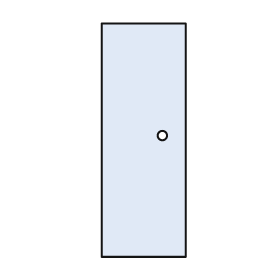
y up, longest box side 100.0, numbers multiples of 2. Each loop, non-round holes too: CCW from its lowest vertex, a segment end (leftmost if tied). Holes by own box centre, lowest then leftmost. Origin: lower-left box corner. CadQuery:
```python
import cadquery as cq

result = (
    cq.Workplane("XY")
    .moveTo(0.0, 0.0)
    .lineTo(36.0, 0.0)
    .lineTo(36.0, 100.0)
    .lineTo(0.0, 100.0)
    .close()
    .moveTo(26.0, 52.0)
    .circle(2.0)
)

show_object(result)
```